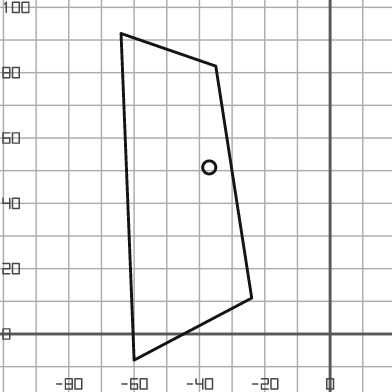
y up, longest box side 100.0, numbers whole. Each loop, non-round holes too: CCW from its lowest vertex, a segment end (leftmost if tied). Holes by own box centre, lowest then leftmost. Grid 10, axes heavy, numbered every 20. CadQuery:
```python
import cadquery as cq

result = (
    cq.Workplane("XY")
    .moveTo(-60.0, -8.0)
    .lineTo(-24.0, 11.0)
    .lineTo(-35.0, 82.0)
    .lineTo(-64.0, 92.0)
    .close()
    .moveTo(-37.0, 51.0)
    .circle(2.0)
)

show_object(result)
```